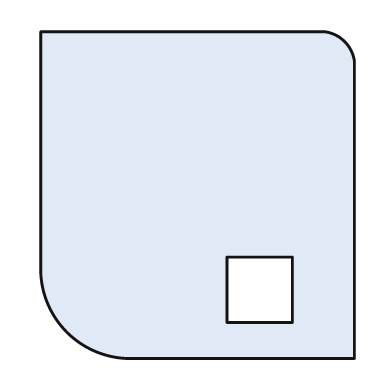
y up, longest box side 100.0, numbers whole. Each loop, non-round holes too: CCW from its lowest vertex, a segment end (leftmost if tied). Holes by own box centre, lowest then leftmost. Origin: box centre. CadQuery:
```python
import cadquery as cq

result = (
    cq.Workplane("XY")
    .moveTo(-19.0, -50.0)
    .lineTo(48.0, -50.0)
    .lineTo(48.0, 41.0)
    .threePointArc((45.0, 47.0), (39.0, 50.0))
    .lineTo(-48.0, 50.0)
    .lineTo(-48.0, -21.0)
    .threePointArc((-40.0, -42.0), (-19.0, -50.0))
    .close()
    .moveTo(9.0, -39.0)
    .lineTo(29.0, -39.0)
    .lineTo(29.0, -19.0)
    .lineTo(9.0, -19.0)
    .close()
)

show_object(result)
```